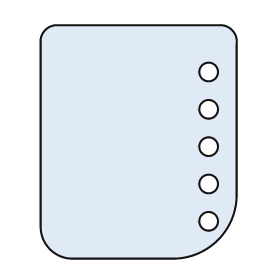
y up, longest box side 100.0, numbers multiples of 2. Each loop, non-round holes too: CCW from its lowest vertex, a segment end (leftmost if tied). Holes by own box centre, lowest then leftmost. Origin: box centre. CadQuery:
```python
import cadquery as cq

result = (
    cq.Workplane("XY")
    .moveTo(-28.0, -50.0)
    .lineTo(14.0, -50.0)
    .threePointArc((34.0, -42.0), (42.0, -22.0))
    .lineTo(42.0, 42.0)
    .threePointArc((40.0, 48.0), (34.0, 50.0))
    .lineTo(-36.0, 50.0)
    .threePointArc((-40.0, 48.0), (-42.0, 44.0))
    .lineTo(-42.0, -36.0)
    .threePointArc((-38.0, -46.0), (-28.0, -50.0))
    .close()
    .moveTo(30.0, -34.0)
    .circle(4.0)
    .moveTo(30.0, -18.0)
    .circle(4.0)
    .moveTo(30.0, -2.0)
    .circle(4.0)
    .moveTo(30.0, 14.0)
    .circle(4.0)
    .moveTo(30.0, 30.0)
    .circle(4.0)
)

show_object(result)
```